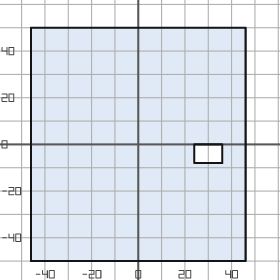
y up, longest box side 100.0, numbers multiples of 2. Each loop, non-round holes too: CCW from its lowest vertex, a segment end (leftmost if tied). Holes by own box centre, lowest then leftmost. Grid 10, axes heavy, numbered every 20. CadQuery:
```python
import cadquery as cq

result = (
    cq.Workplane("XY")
    .moveTo(-46.0, -50.0)
    .lineTo(46.0, -50.0)
    .lineTo(46.0, 50.0)
    .lineTo(-46.0, 50.0)
    .close()
    .moveTo(24.0, -8.0)
    .lineTo(36.0, -8.0)
    .lineTo(36.0, 0.0)
    .lineTo(24.0, 0.0)
    .close()
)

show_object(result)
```